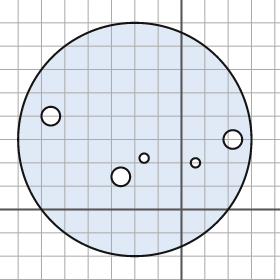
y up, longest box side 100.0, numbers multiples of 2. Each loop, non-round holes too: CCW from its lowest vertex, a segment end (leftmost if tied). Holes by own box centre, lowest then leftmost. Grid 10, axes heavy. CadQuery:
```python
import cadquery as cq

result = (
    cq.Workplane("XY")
    .moveTo(-20.0, 30.0)
    .circle(50.0)
    .moveTo(-26.0, 14.0)
    .circle(4.0)
    .moveTo(6.0, 20.0)
    .circle(2.0)
    .moveTo(-16.0, 22.0)
    .circle(2.0)
    .moveTo(22.0, 30.0)
    .circle(4.0)
    .moveTo(-56.0, 40.0)
    .circle(4.0)
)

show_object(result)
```